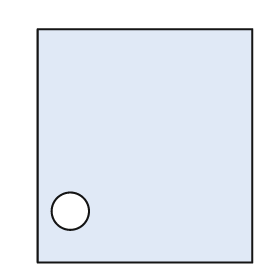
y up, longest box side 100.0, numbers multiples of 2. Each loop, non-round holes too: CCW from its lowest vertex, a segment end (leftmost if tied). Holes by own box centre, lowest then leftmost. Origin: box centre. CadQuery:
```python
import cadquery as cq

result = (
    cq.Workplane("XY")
    .moveTo(-46.0, -50.0)
    .lineTo(46.0, -50.0)
    .lineTo(46.0, 50.0)
    .lineTo(-46.0, 50.0)
    .close()
    .moveTo(-32.0, -28.0)
    .circle(8.0)
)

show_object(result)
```